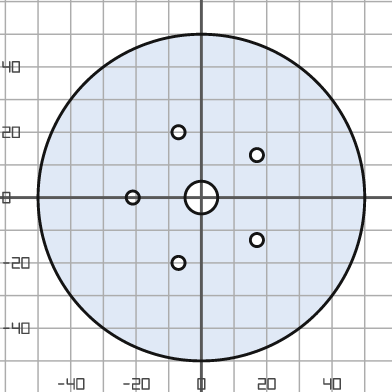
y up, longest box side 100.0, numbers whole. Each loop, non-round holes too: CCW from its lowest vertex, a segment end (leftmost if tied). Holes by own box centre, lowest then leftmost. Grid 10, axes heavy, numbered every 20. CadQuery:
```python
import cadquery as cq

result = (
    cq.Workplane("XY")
    .moveTo(0.0, 0.0)
    .circle(50.0)
    .moveTo(-7.0, -20.0)
    .circle(2.0)
    .moveTo(17.0, -13.0)
    .circle(2.0)
    .moveTo(-21.0, 0.0)
    .circle(2.0)
    .moveTo(0.0, 0.0)
    .circle(5.0)
    .moveTo(17.0, 13.0)
    .circle(2.0)
    .moveTo(-7.0, 20.0)
    .circle(2.0)
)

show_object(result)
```